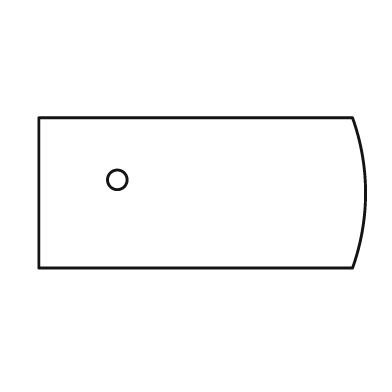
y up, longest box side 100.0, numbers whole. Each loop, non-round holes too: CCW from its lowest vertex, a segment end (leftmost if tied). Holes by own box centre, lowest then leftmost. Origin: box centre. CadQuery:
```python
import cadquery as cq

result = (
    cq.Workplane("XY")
    .moveTo(-50.0, -23.0)
    .lineTo(46.0, -23.0)
    .threePointArc((50.0, 0.0), (46.0, 23.0))
    .lineTo(-50.0, 23.0)
    .close()
    .moveTo(-26.0, 4.0)
    .circle(3.0)
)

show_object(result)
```